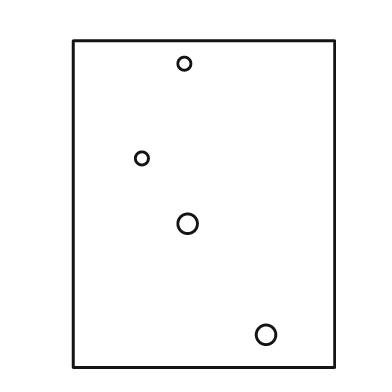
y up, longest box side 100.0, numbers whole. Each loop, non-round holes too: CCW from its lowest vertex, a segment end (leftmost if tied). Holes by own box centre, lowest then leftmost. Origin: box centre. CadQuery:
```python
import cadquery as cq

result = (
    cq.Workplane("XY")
    .moveTo(-40.0, -50.0)
    .lineTo(40.0, -50.0)
    .lineTo(40.0, 50.0)
    .lineTo(-40.0, 50.0)
    .close()
    .moveTo(19.0, -40.0)
    .circle(3.0)
    .moveTo(-5.0, -6.0)
    .circle(3.0)
    .moveTo(-19.0, 14.0)
    .circle(2.0)
    .moveTo(-6.0, 43.0)
    .circle(2.0)
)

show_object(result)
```